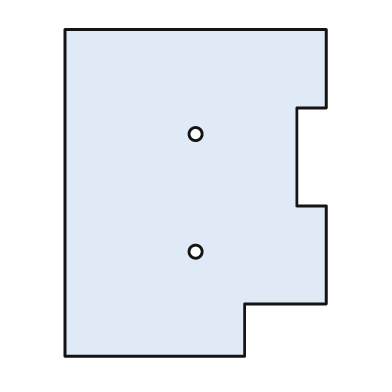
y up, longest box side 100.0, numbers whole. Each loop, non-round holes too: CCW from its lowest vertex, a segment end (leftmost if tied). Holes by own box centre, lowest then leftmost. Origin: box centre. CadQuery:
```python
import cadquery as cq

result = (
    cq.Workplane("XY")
    .moveTo(-40.0, -50.0)
    .lineTo(15.0, -50.0)
    .lineTo(15.0, -34.0)
    .lineTo(40.0, -34.0)
    .lineTo(40.0, -4.0)
    .lineTo(31.0, -4.0)
    .lineTo(31.0, 26.0)
    .lineTo(40.0, 26.0)
    .lineTo(40.0, 50.0)
    .lineTo(-40.0, 50.0)
    .close()
    .moveTo(0.0, -18.0)
    .circle(2.0)
    .moveTo(0.0, 18.0)
    .circle(2.0)
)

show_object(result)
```